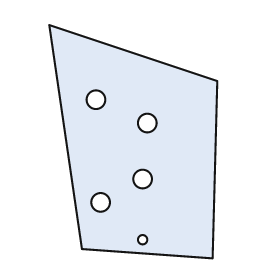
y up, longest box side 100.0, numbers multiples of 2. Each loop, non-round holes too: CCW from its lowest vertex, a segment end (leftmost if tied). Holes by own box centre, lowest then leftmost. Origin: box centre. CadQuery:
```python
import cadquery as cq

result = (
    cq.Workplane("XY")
    .moveTo(34.0, -50.0)
    .lineTo(36.0, 26.0)
    .lineTo(-36.0, 50.0)
    .lineTo(-22.0, -46.0)
    .close()
    .moveTo(4.0, -42.0)
    .circle(2.0)
    .moveTo(-14.0, -26.0)
    .circle(4.0)
    .moveTo(4.0, -16.0)
    .circle(4.0)
    .moveTo(6.0, 8.0)
    .circle(4.0)
    .moveTo(-16.0, 18.0)
    .circle(4.0)
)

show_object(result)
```